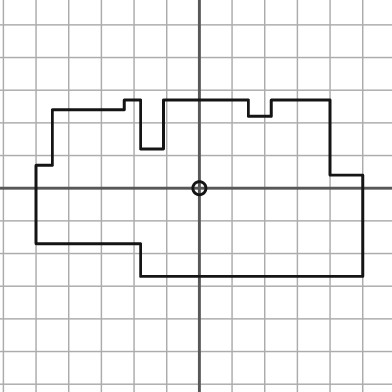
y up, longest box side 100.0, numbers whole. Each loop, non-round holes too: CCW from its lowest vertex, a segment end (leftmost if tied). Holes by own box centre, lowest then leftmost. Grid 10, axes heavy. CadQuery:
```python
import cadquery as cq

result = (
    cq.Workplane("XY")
    .moveTo(-18.0, -27.0)
    .lineTo(50.0, -27.0)
    .lineTo(50.0, 4.0)
    .lineTo(40.0, 4.0)
    .lineTo(40.0, 27.0)
    .lineTo(22.0, 27.0)
    .lineTo(22.0, 22.0)
    .lineTo(15.0, 22.0)
    .lineTo(15.0, 27.0)
    .lineTo(-11.0, 27.0)
    .lineTo(-11.0, 12.0)
    .lineTo(-18.0, 12.0)
    .lineTo(-18.0, 27.0)
    .lineTo(-23.0, 27.0)
    .lineTo(-23.0, 24.0)
    .lineTo(-45.0, 24.0)
    .lineTo(-45.0, 7.0)
    .lineTo(-50.0, 7.0)
    .lineTo(-50.0, -17.0)
    .lineTo(-18.0, -17.0)
    .close()
    .moveTo(0.0, 0.0)
    .circle(2.0)
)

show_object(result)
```